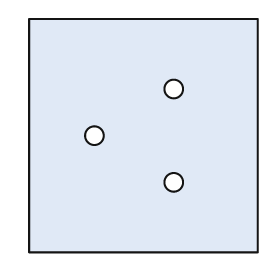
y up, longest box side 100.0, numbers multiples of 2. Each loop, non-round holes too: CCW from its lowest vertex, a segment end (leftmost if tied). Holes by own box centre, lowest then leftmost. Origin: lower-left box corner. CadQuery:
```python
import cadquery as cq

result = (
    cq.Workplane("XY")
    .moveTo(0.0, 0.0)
    .lineTo(98.0, 0.0)
    .lineTo(98.0, 100.0)
    .lineTo(0.0, 100.0)
    .close()
    .moveTo(62.0, 30.0)
    .circle(4.0)
    .moveTo(28.0, 50.0)
    .circle(4.0)
    .moveTo(62.0, 70.0)
    .circle(4.0)
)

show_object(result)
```